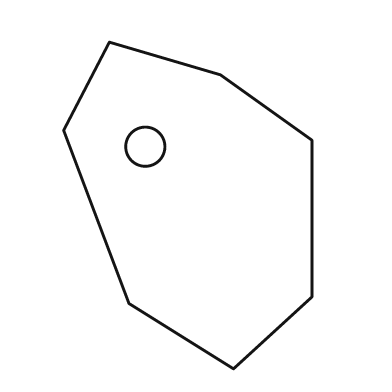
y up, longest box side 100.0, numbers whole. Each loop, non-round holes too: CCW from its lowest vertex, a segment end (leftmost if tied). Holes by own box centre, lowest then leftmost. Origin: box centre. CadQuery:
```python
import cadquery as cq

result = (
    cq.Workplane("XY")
    .moveTo(14.0, -50.0)
    .lineTo(38.0, -28.0)
    .lineTo(38.0, 20.0)
    .lineTo(10.0, 40.0)
    .lineTo(-24.0, 50.0)
    .lineTo(-38.0, 23.0)
    .lineTo(-18.0, -30.0)
    .close()
    .moveTo(-13.0, 18.0)
    .circle(6.0)
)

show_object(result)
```